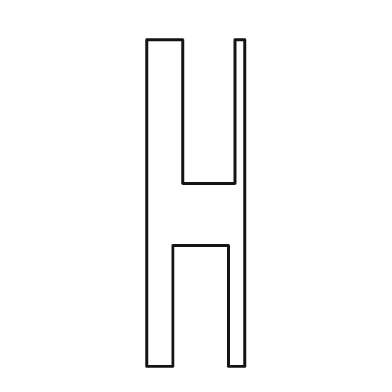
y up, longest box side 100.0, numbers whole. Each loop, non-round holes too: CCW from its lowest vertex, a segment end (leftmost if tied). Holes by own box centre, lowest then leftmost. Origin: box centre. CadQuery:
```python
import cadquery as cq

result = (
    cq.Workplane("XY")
    .moveTo(-15.0, -50.0)
    .lineTo(-7.0, -50.0)
    .lineTo(-7.0, -13.0)
    .lineTo(10.0, -13.0)
    .lineTo(10.0, -50.0)
    .lineTo(15.0, -50.0)
    .lineTo(15.0, 50.0)
    .lineTo(12.0, 50.0)
    .lineTo(12.0, 6.0)
    .lineTo(-4.0, 6.0)
    .lineTo(-4.0, 50.0)
    .lineTo(-15.0, 50.0)
    .close()
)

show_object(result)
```